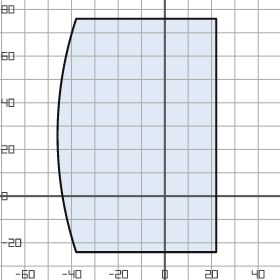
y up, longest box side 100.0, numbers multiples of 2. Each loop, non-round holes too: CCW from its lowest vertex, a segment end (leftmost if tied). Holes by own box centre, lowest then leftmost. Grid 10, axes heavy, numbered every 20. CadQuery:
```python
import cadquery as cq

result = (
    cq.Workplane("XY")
    .moveTo(-38.0, -24.0)
    .lineTo(22.0, -24.0)
    .lineTo(22.0, 76.0)
    .lineTo(-38.0, 76.0)
    .threePointArc((-46.0, 26.0), (-38.0, -24.0))
    .close()
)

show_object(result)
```